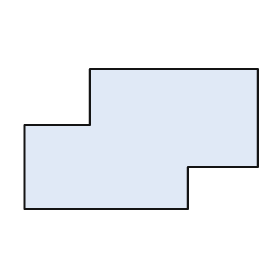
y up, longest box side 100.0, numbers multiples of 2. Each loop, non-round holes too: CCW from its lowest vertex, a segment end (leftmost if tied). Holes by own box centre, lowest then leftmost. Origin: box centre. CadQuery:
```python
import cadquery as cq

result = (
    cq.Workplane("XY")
    .moveTo(-50.0, -30.0)
    .lineTo(20.0, -30.0)
    .lineTo(20.0, -12.0)
    .lineTo(50.0, -12.0)
    .lineTo(50.0, 30.0)
    .lineTo(-22.0, 30.0)
    .lineTo(-22.0, 6.0)
    .lineTo(-50.0, 6.0)
    .close()
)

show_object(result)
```